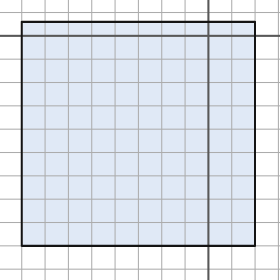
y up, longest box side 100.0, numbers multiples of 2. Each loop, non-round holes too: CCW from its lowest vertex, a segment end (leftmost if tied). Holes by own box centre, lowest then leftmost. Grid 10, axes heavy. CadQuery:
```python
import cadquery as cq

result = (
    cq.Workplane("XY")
    .moveTo(-80.0, -90.0)
    .lineTo(20.0, -90.0)
    .lineTo(20.0, 6.0)
    .lineTo(-80.0, 6.0)
    .close()
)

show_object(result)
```